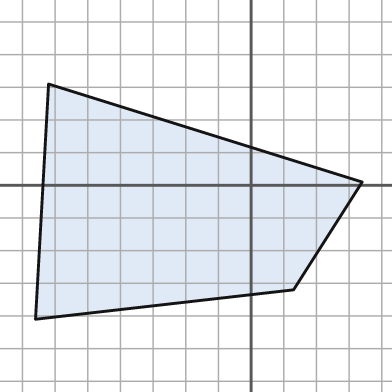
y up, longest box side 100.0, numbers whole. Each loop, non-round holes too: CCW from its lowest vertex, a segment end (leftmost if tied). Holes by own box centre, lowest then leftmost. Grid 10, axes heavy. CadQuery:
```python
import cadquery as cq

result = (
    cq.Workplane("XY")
    .moveTo(-66.0, -41.0)
    .lineTo(13.0, -32.0)
    .lineTo(34.0, 1.0)
    .lineTo(-62.0, 31.0)
    .close()
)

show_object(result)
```